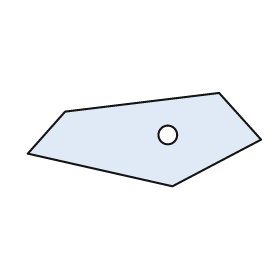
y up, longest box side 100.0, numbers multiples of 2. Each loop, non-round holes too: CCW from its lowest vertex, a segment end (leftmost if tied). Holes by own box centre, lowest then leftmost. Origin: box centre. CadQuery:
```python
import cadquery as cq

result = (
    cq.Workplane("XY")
    .moveTo(12.0, -20.0)
    .lineTo(50.0, 0.0)
    .lineTo(32.0, 20.0)
    .lineTo(-34.0, 12.0)
    .lineTo(-50.0, -6.0)
    .close()
    .moveTo(10.0, 2.0)
    .circle(4.0)
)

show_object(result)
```